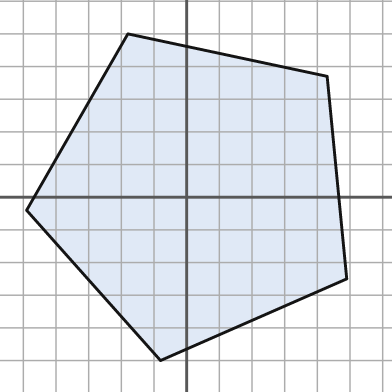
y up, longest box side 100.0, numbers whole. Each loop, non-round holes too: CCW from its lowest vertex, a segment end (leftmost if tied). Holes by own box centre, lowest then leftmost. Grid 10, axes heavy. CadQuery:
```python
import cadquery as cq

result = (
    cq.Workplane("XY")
    .moveTo(-8.0, -50.0)
    .lineTo(49.0, -25.0)
    .lineTo(43.0, 37.0)
    .lineTo(-18.0, 50.0)
    .lineTo(-49.0, -4.0)
    .close()
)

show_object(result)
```